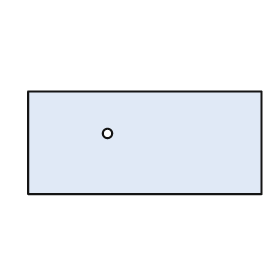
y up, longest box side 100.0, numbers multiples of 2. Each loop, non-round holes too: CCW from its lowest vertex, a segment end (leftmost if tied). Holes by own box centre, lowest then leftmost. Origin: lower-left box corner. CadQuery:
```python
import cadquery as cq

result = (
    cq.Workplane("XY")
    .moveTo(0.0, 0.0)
    .lineTo(100.0, 0.0)
    .lineTo(100.0, 44.0)
    .lineTo(0.0, 44.0)
    .close()
    .moveTo(34.0, 26.0)
    .circle(2.0)
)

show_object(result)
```